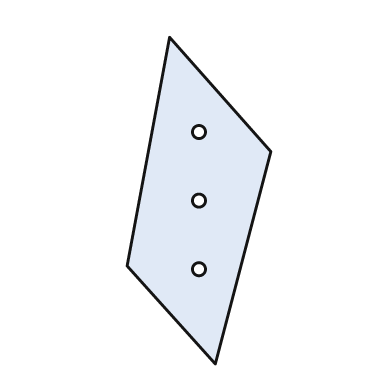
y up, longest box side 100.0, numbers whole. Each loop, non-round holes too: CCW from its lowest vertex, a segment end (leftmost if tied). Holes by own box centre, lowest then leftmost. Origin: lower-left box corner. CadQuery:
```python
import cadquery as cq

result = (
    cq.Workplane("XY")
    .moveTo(27.0, 0.0)
    .lineTo(44.0, 65.0)
    .lineTo(13.0, 100.0)
    .lineTo(0.0, 30.0)
    .close()
    .moveTo(22.0, 29.0)
    .circle(2.0)
    .moveTo(22.0, 50.0)
    .circle(2.0)
    .moveTo(22.0, 71.0)
    .circle(2.0)
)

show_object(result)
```